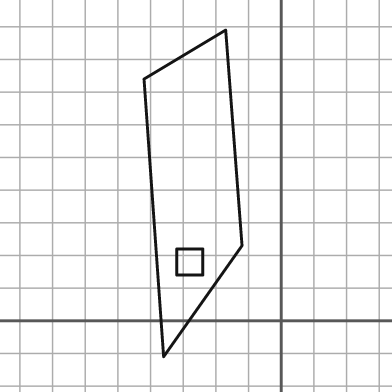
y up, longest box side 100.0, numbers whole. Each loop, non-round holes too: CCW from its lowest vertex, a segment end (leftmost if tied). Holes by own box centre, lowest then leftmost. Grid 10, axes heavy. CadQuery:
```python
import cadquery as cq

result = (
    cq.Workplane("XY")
    .moveTo(-36.0, -11.0)
    .lineTo(-12.0, 23.0)
    .lineTo(-17.0, 89.0)
    .lineTo(-42.0, 74.0)
    .close()
    .moveTo(-32.0, 14.0)
    .lineTo(-24.0, 14.0)
    .lineTo(-24.0, 22.0)
    .lineTo(-32.0, 22.0)
    .close()
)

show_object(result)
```